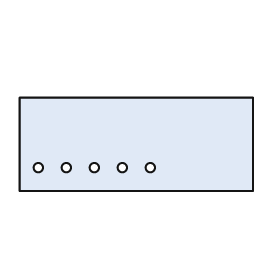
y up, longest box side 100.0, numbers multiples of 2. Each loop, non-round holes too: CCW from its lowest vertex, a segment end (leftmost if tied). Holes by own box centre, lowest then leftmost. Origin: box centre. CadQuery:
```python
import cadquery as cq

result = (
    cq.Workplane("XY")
    .moveTo(-50.0, -20.0)
    .lineTo(50.0, -20.0)
    .lineTo(50.0, 20.0)
    .lineTo(-50.0, 20.0)
    .close()
    .moveTo(-42.0, -10.0)
    .circle(2.0)
    .moveTo(-30.0, -10.0)
    .circle(2.0)
    .moveTo(-18.0, -10.0)
    .circle(2.0)
    .moveTo(-6.0, -10.0)
    .circle(2.0)
    .moveTo(6.0, -10.0)
    .circle(2.0)
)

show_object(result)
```